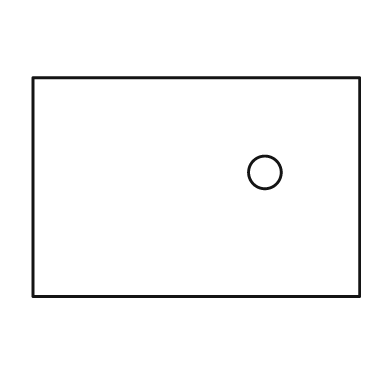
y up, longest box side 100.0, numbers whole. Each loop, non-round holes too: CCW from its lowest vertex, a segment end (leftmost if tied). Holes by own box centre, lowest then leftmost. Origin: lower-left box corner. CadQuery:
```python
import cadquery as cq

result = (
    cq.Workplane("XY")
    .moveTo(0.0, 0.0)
    .lineTo(100.0, 0.0)
    .lineTo(100.0, 67.0)
    .lineTo(0.0, 67.0)
    .close()
    .moveTo(71.0, 38.0)
    .circle(5.0)
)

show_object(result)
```